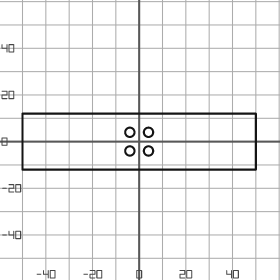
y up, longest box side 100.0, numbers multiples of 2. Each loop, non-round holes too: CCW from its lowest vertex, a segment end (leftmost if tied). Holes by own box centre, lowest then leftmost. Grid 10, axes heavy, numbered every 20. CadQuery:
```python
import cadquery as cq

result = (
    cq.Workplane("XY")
    .moveTo(-50.0, -12.0)
    .lineTo(50.0, -12.0)
    .lineTo(50.0, 12.0)
    .lineTo(-50.0, 12.0)
    .close()
    .moveTo(-4.0, -4.0)
    .circle(2.0)
    .moveTo(4.0, -4.0)
    .circle(2.0)
    .moveTo(-4.0, 4.0)
    .circle(2.0)
    .moveTo(4.0, 4.0)
    .circle(2.0)
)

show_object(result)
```